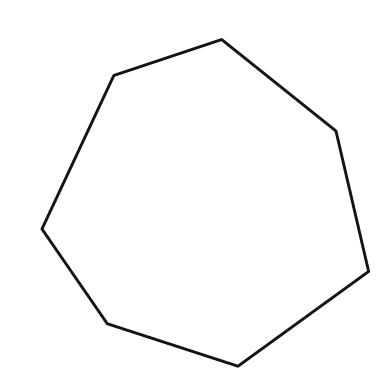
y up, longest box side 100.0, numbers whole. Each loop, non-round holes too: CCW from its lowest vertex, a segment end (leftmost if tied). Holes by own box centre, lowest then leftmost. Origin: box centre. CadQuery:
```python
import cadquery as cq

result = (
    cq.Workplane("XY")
    .moveTo(10.0, -50.0)
    .lineTo(50.0, -21.0)
    .lineTo(40.0, 22.0)
    .lineTo(5.0, 50.0)
    .lineTo(-28.0, 39.0)
    .lineTo(-50.0, -8.0)
    .lineTo(-30.0, -37.0)
    .close()
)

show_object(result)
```